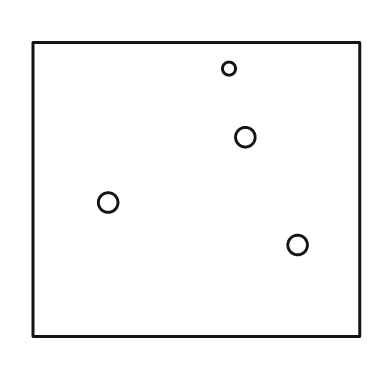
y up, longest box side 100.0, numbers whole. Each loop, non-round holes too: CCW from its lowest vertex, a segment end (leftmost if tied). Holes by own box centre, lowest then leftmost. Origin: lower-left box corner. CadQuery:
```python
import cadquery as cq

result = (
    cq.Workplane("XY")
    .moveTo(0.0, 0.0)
    .lineTo(100.0, 0.0)
    .lineTo(100.0, 90.0)
    .lineTo(0.0, 90.0)
    .close()
    .moveTo(81.0, 28.0)
    .circle(3.0)
    .moveTo(23.0, 41.0)
    .circle(3.0)
    .moveTo(65.0, 61.0)
    .circle(3.0)
    .moveTo(60.0, 82.0)
    .circle(2.0)
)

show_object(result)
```